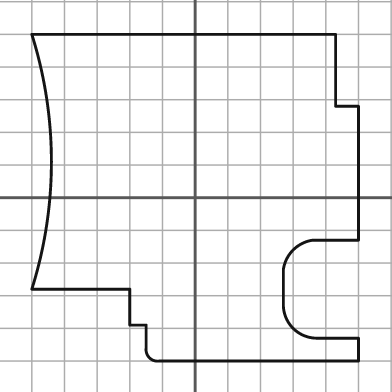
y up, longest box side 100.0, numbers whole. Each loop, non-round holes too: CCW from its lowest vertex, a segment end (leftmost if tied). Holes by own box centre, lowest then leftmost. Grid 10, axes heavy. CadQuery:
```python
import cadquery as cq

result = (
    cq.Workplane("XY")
    .moveTo(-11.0, -50.0)
    .lineTo(50.0, -50.0)
    .lineTo(50.0, -43.0)
    .lineTo(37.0, -43.0)
    .threePointArc((30.0, -40.0), (27.0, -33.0))
    .lineTo(27.0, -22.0)
    .threePointArc((30.0, -16.0), (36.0, -13.0))
    .lineTo(50.0, -13.0)
    .lineTo(50.0, 28.0)
    .lineTo(43.0, 28.0)
    .lineTo(43.0, 50.0)
    .lineTo(-50.0, 50.0)
    .threePointArc((-44.0, 11.0), (-50.0, -28.0))
    .lineTo(-20.0, -28.0)
    .lineTo(-20.0, -39.0)
    .lineTo(-15.0, -39.0)
    .lineTo(-15.0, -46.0)
    .threePointArc((-14.0, -49.0), (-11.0, -50.0))
    .close()
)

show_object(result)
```